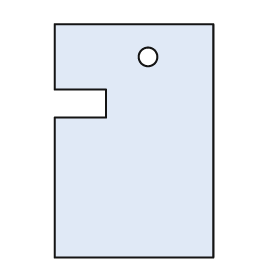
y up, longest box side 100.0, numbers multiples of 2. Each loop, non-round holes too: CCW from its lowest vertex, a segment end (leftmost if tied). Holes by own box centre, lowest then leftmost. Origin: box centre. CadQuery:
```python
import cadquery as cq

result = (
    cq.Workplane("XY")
    .moveTo(-34.0, -50.0)
    .lineTo(34.0, -50.0)
    .lineTo(34.0, 50.0)
    .lineTo(-34.0, 50.0)
    .lineTo(-34.0, 22.0)
    .lineTo(-12.0, 22.0)
    .lineTo(-12.0, 10.0)
    .lineTo(-34.0, 10.0)
    .close()
    .moveTo(6.0, 36.0)
    .circle(4.0)
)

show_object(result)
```